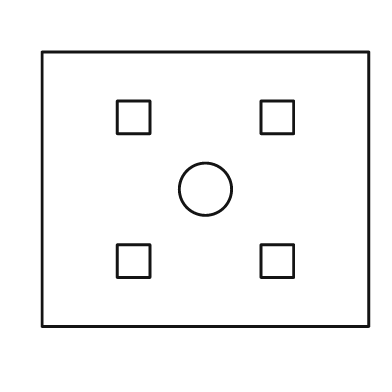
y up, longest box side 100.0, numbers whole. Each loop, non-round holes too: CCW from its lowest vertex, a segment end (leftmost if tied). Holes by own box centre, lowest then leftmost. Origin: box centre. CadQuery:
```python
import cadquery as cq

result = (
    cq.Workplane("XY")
    .moveTo(-50.0, -42.0)
    .lineTo(50.0, -42.0)
    .lineTo(50.0, 42.0)
    .lineTo(-50.0, 42.0)
    .close()
    .moveTo(-27.0, -27.0)
    .lineTo(-17.0, -27.0)
    .lineTo(-17.0, -17.0)
    .lineTo(-27.0, -17.0)
    .close()
    .moveTo(17.0, -27.0)
    .lineTo(27.0, -27.0)
    .lineTo(27.0, -17.0)
    .lineTo(17.0, -17.0)
    .close()
    .moveTo(0.0, 0.0)
    .circle(8.0)
    .moveTo(-27.0, 17.0)
    .lineTo(-17.0, 17.0)
    .lineTo(-17.0, 27.0)
    .lineTo(-27.0, 27.0)
    .close()
    .moveTo(17.0, 17.0)
    .lineTo(27.0, 17.0)
    .lineTo(27.0, 27.0)
    .lineTo(17.0, 27.0)
    .close()
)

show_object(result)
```